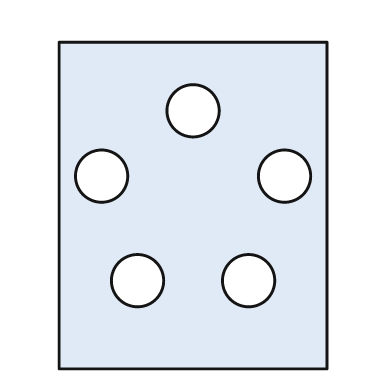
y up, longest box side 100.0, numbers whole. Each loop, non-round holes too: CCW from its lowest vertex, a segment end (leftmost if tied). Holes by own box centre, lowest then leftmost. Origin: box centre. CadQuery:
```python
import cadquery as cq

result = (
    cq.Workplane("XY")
    .moveTo(-41.0, -50.0)
    .lineTo(41.0, -50.0)
    .lineTo(41.0, 50.0)
    .lineTo(-41.0, 50.0)
    .close()
    .moveTo(-17.0, -23.0)
    .circle(8.0)
    .moveTo(17.0, -23.0)
    .circle(8.0)
    .moveTo(-28.0, 9.0)
    .circle(8.0)
    .moveTo(28.0, 9.0)
    .circle(8.0)
    .moveTo(0.0, 29.0)
    .circle(8.0)
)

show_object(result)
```